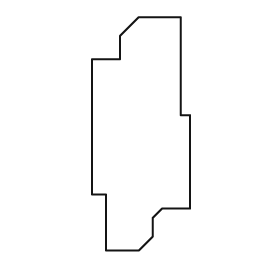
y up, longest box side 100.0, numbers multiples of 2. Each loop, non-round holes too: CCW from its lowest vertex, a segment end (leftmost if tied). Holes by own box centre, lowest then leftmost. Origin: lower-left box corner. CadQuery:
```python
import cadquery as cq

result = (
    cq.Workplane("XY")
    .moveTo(6.0, 0.0)
    .lineTo(20.0, 0.0)
    .lineTo(26.0, 6.0)
    .lineTo(26.0, 14.0)
    .lineTo(30.0, 18.0)
    .lineTo(42.0, 18.0)
    .lineTo(42.0, 58.0)
    .lineTo(38.0, 58.0)
    .lineTo(38.0, 100.0)
    .lineTo(20.0, 100.0)
    .lineTo(12.0, 92.0)
    .lineTo(12.0, 82.0)
    .lineTo(0.0, 82.0)
    .lineTo(0.0, 24.0)
    .lineTo(6.0, 24.0)
    .close()
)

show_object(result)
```